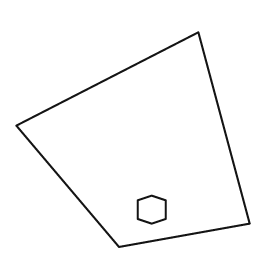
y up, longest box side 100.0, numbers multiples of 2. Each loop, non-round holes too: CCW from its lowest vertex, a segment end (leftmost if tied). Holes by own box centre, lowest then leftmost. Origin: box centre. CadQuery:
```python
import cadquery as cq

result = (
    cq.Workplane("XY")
    .moveTo(-6.0, -46.0)
    .lineTo(50.0, -36.0)
    .lineTo(28.0, 46.0)
    .lineTo(-50.0, 6.0)
    .close()
    .moveTo(8.0, -36.0)
    .lineTo(14.0, -34.0)
    .lineTo(14.0, -26.0)
    .lineTo(8.0, -24.0)
    .lineTo(2.0, -26.0)
    .lineTo(2.0, -34.0)
    .close()
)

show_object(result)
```